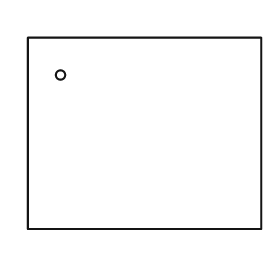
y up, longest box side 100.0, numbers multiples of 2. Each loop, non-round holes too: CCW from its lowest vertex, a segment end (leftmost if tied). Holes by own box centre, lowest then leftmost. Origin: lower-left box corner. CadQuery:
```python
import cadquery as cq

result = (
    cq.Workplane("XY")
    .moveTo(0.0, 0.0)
    .lineTo(100.0, 0.0)
    .lineTo(100.0, 82.0)
    .lineTo(0.0, 82.0)
    .close()
    .moveTo(14.0, 66.0)
    .circle(2.0)
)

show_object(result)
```